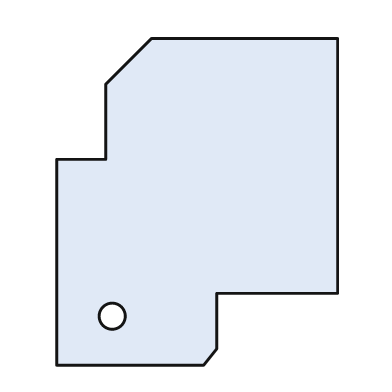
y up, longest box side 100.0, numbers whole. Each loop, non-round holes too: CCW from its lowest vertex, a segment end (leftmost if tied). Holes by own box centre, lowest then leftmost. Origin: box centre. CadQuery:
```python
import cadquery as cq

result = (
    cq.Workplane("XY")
    .moveTo(-43.0, -50.0)
    .lineTo(2.0, -50.0)
    .lineTo(6.0, -45.0)
    .lineTo(6.0, -28.0)
    .lineTo(43.0, -28.0)
    .lineTo(43.0, 50.0)
    .lineTo(-14.0, 50.0)
    .lineTo(-28.0, 36.0)
    .lineTo(-28.0, 13.0)
    .lineTo(-43.0, 13.0)
    .close()
    .moveTo(-26.0, -35.0)
    .circle(4.0)
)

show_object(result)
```